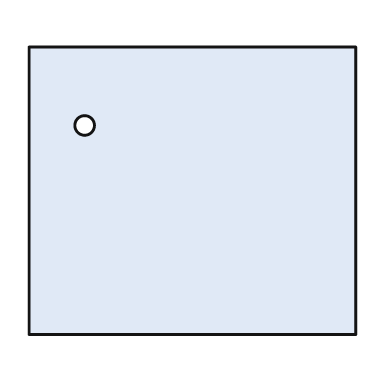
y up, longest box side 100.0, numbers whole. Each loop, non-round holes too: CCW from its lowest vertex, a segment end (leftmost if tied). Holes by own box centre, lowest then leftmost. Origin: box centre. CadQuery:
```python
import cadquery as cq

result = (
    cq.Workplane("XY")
    .moveTo(-50.0, -44.0)
    .lineTo(50.0, -44.0)
    .lineTo(50.0, 44.0)
    .lineTo(-50.0, 44.0)
    .close()
    .moveTo(-33.0, 20.0)
    .circle(3.0)
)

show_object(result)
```